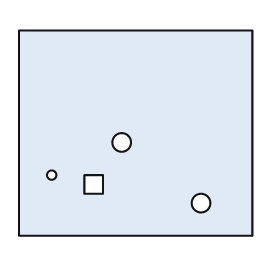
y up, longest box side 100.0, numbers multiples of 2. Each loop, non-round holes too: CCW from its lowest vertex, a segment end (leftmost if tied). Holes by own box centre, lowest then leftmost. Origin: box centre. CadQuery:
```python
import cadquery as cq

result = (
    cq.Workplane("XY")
    .moveTo(-50.0, -44.0)
    .lineTo(50.0, -44.0)
    .lineTo(50.0, 44.0)
    .lineTo(-50.0, 44.0)
    .close()
    .moveTo(28.0, -30.0)
    .circle(4.0)
    .moveTo(-22.0, -26.0)
    .lineTo(-14.0, -26.0)
    .lineTo(-14.0, -18.0)
    .lineTo(-22.0, -18.0)
    .close()
    .moveTo(-36.0, -18.0)
    .circle(2.0)
    .moveTo(-6.0, -4.0)
    .circle(4.0)
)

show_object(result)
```